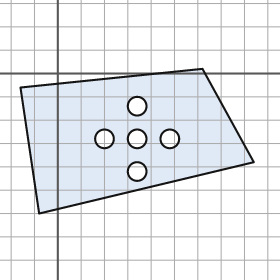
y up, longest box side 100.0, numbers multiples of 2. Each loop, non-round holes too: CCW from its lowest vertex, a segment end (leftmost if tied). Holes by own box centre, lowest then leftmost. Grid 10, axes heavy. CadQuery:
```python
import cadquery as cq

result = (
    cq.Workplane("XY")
    .moveTo(-8.0, -60.0)
    .lineTo(84.0, -38.0)
    .lineTo(62.0, 2.0)
    .lineTo(-16.0, -6.0)
    .close()
    .moveTo(34.0, -42.0)
    .circle(4.0)
    .moveTo(20.0, -28.0)
    .circle(4.0)
    .moveTo(34.0, -28.0)
    .circle(4.0)
    .moveTo(48.0, -28.0)
    .circle(4.0)
    .moveTo(34.0, -14.0)
    .circle(4.0)
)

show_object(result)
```